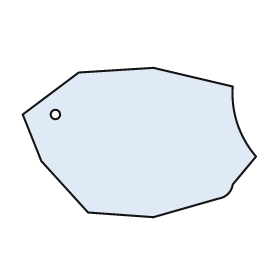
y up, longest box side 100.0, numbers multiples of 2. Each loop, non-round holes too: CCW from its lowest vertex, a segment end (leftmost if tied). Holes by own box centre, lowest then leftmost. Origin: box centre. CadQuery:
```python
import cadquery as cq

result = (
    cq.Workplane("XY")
    .moveTo(6.0, -32.0)
    .lineTo(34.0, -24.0)
    .threePointArc((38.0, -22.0), (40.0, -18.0))
    .lineTo(50.0, -6.0)
    .threePointArc((42.0, 8.0), (40.0, 24.0))
    .lineTo(6.0, 32.0)
    .lineTo(-26.0, 30.0)
    .lineTo(-50.0, 12.0)
    .lineTo(-42.0, -8.0)
    .lineTo(-22.0, -30.0)
    .close()
    .moveTo(-36.0, 12.0)
    .circle(2.0)
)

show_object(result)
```